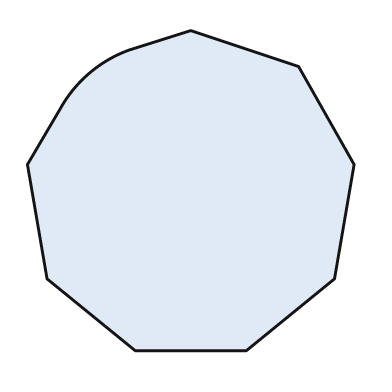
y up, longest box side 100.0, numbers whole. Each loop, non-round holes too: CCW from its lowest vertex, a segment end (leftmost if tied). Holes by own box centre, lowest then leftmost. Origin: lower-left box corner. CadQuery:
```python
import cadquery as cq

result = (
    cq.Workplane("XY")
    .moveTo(33.0, 0.0)
    .lineTo(67.0, 0.0)
    .lineTo(94.0, 22.0)
    .lineTo(100.0, 57.0)
    .lineTo(83.0, 87.0)
    .lineTo(50.0, 98.0)
    .lineTo(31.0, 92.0)
    .threePointArc((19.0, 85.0), (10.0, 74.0))
    .lineTo(0.0, 57.0)
    .lineTo(6.0, 22.0)
    .close()
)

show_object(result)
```